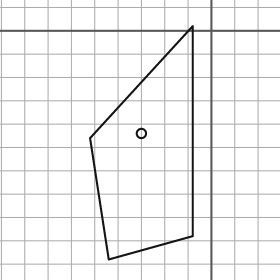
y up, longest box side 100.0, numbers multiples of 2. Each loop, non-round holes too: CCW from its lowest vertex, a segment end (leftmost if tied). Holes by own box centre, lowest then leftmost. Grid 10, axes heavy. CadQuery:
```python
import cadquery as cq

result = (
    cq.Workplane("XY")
    .moveTo(-44.0, -98.0)
    .lineTo(-8.0, -88.0)
    .lineTo(-8.0, 2.0)
    .lineTo(-52.0, -46.0)
    .close()
    .moveTo(-30.0, -44.0)
    .circle(2.0)
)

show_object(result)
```